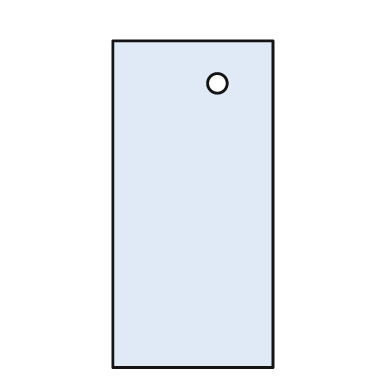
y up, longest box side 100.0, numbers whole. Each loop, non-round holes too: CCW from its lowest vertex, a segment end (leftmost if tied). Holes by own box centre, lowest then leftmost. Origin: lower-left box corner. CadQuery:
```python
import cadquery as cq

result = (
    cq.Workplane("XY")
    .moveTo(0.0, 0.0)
    .lineTo(49.0, 0.0)
    .lineTo(49.0, 100.0)
    .lineTo(0.0, 100.0)
    .close()
    .moveTo(32.0, 87.0)
    .circle(3.0)
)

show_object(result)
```